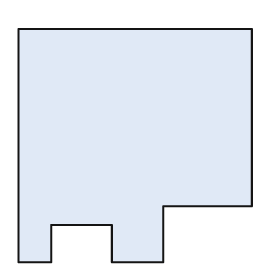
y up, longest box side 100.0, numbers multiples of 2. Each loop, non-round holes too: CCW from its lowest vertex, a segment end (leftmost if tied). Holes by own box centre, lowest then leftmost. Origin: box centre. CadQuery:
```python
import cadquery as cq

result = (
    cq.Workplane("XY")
    .moveTo(-50.0, -50.0)
    .lineTo(-36.0, -50.0)
    .lineTo(-36.0, -34.0)
    .lineTo(-10.0, -34.0)
    .lineTo(-10.0, -50.0)
    .lineTo(12.0, -50.0)
    .lineTo(12.0, -26.0)
    .lineTo(50.0, -26.0)
    .lineTo(50.0, 50.0)
    .lineTo(-50.0, 50.0)
    .close()
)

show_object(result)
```